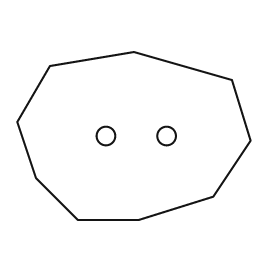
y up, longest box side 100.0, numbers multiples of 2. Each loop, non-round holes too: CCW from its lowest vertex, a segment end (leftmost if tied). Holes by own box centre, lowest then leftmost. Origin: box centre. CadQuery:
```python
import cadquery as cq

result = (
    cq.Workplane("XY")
    .moveTo(-24.0, -36.0)
    .lineTo(2.0, -36.0)
    .lineTo(34.0, -26.0)
    .lineTo(50.0, -2.0)
    .lineTo(42.0, 24.0)
    .lineTo(0.0, 36.0)
    .lineTo(-36.0, 30.0)
    .lineTo(-50.0, 6.0)
    .lineTo(-42.0, -18.0)
    .close()
    .moveTo(-12.0, 0.0)
    .circle(4.0)
    .moveTo(14.0, 0.0)
    .circle(4.0)
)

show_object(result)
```